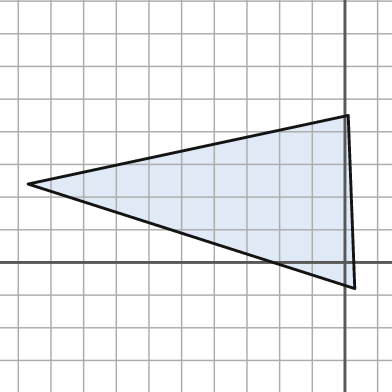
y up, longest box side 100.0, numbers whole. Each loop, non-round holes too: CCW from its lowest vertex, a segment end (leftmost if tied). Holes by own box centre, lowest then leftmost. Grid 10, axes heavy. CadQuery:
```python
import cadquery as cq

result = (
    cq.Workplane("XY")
    .moveTo(3.0, -8.0)
    .lineTo(1.0, 45.0)
    .lineTo(-97.0, 24.0)
    .close()
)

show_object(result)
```